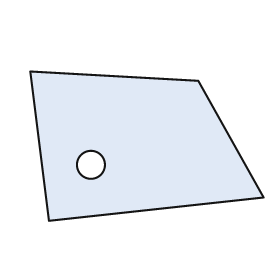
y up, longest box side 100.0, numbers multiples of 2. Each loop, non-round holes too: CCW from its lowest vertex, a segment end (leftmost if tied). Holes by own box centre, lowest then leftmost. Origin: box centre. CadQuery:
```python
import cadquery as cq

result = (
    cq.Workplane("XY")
    .moveTo(-42.0, -32.0)
    .lineTo(50.0, -22.0)
    .lineTo(22.0, 28.0)
    .lineTo(-50.0, 32.0)
    .close()
    .moveTo(-24.0, -8.0)
    .circle(6.0)
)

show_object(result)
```